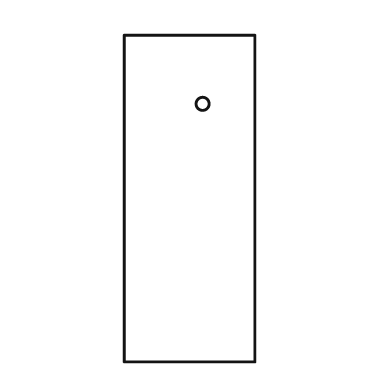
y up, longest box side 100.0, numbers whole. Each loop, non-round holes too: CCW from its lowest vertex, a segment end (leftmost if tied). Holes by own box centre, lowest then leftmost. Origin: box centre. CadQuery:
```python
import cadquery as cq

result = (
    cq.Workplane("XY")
    .moveTo(-20.0, -50.0)
    .lineTo(20.0, -50.0)
    .lineTo(20.0, 50.0)
    .lineTo(-20.0, 50.0)
    .close()
    .moveTo(4.0, 29.0)
    .circle(2.0)
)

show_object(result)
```